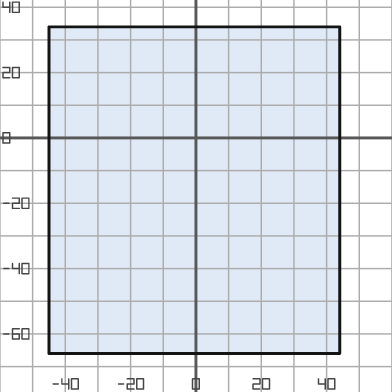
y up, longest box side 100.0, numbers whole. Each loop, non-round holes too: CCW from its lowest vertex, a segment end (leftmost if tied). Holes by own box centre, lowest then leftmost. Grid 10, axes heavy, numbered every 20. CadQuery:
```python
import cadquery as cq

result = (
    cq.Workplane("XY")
    .moveTo(-45.0, -66.0)
    .lineTo(44.0, -66.0)
    .lineTo(44.0, 34.0)
    .lineTo(-45.0, 34.0)
    .close()
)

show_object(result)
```